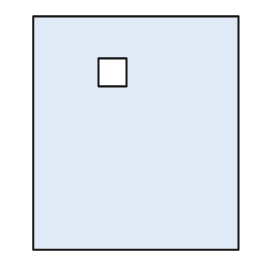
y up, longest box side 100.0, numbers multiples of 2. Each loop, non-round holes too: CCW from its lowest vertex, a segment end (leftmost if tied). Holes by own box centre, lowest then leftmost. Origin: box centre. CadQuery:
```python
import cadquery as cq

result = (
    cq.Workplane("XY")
    .moveTo(-44.0, -50.0)
    .lineTo(44.0, -50.0)
    .lineTo(44.0, 50.0)
    .lineTo(-44.0, 50.0)
    .close()
    .moveTo(-16.0, 20.0)
    .lineTo(-4.0, 20.0)
    .lineTo(-4.0, 32.0)
    .lineTo(-16.0, 32.0)
    .close()
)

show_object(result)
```